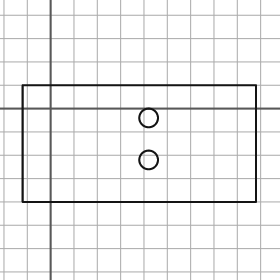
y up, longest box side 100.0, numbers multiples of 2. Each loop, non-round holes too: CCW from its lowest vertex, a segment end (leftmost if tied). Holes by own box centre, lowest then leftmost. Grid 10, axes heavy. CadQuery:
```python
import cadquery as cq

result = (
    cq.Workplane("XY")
    .moveTo(-12.0, -40.0)
    .lineTo(88.0, -40.0)
    .lineTo(88.0, 10.0)
    .lineTo(-12.0, 10.0)
    .close()
    .moveTo(42.0, -22.0)
    .circle(4.0)
    .moveTo(42.0, -4.0)
    .circle(4.0)
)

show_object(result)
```